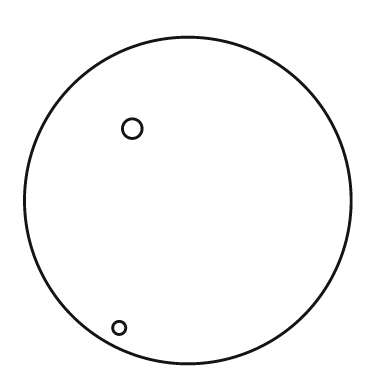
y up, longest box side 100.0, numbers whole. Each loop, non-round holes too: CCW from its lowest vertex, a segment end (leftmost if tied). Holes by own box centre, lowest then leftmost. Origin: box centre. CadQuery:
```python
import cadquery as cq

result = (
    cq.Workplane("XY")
    .moveTo(0.0, 0.0)
    .circle(50.0)
    .moveTo(-21.0, -39.0)
    .circle(2.0)
    .moveTo(-17.0, 22.0)
    .circle(3.0)
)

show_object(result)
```